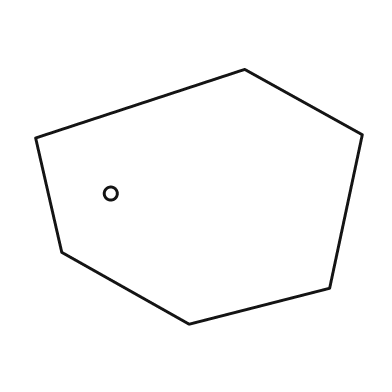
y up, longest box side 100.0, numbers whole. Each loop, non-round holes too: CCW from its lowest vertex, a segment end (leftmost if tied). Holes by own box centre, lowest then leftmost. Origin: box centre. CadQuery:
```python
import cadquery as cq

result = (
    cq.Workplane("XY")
    .moveTo(-3.0, -39.0)
    .lineTo(40.0, -28.0)
    .lineTo(50.0, 19.0)
    .lineTo(14.0, 39.0)
    .lineTo(-50.0, 18.0)
    .lineTo(-42.0, -17.0)
    .close()
    .moveTo(-27.0, 1.0)
    .circle(2.0)
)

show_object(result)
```